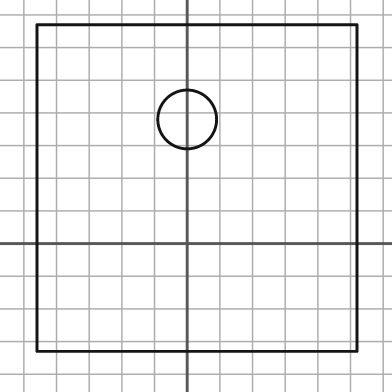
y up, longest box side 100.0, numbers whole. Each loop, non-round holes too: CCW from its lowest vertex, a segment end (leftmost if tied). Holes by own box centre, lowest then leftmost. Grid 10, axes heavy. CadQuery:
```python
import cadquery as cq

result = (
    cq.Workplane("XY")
    .moveTo(-46.0, -33.0)
    .lineTo(52.0, -33.0)
    .lineTo(52.0, 67.0)
    .lineTo(-46.0, 67.0)
    .close()
    .moveTo(0.0, 38.0)
    .circle(9.0)
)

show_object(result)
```